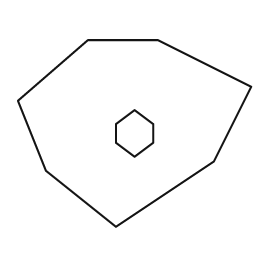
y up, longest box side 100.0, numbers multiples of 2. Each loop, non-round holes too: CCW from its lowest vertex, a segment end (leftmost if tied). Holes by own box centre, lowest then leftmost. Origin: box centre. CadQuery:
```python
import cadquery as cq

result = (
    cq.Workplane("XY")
    .moveTo(-8.0, -40.0)
    .lineTo(34.0, -12.0)
    .lineTo(50.0, 20.0)
    .lineTo(10.0, 40.0)
    .lineTo(-20.0, 40.0)
    .lineTo(-50.0, 14.0)
    .lineTo(-38.0, -16.0)
    .close()
    .moveTo(0.0, -10.0)
    .lineTo(8.0, -4.0)
    .lineTo(8.0, 4.0)
    .lineTo(0.0, 10.0)
    .lineTo(-8.0, 4.0)
    .lineTo(-8.0, -4.0)
    .close()
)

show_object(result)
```